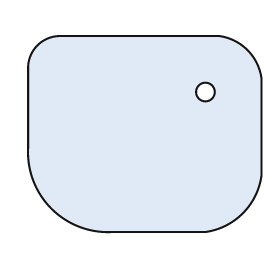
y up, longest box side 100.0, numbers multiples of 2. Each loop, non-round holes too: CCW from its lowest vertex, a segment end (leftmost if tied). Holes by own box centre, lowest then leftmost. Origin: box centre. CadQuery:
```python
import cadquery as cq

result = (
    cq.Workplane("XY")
    .moveTo(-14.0, -42.0)
    .lineTo(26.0, -42.0)
    .threePointArc((42.0, -34.0), (50.0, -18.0))
    .lineTo(50.0, 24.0)
    .threePointArc((44.0, 36.0), (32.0, 42.0))
    .lineTo(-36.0, 42.0)
    .threePointArc((-46.0, 38.0), (-50.0, 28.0))
    .lineTo(-50.0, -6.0)
    .threePointArc((-40.0, -32.0), (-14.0, -42.0))
    .close()
    .moveTo(26.0, 18.0)
    .circle(4.0)
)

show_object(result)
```